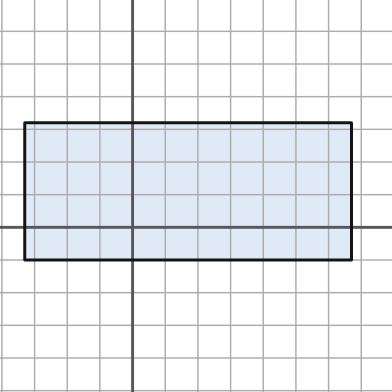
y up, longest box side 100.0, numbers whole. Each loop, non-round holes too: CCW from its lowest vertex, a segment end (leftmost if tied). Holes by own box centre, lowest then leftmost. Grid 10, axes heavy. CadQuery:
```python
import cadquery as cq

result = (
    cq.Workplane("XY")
    .moveTo(-33.0, -10.0)
    .lineTo(67.0, -10.0)
    .lineTo(67.0, 32.0)
    .lineTo(-33.0, 32.0)
    .close()
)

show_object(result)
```